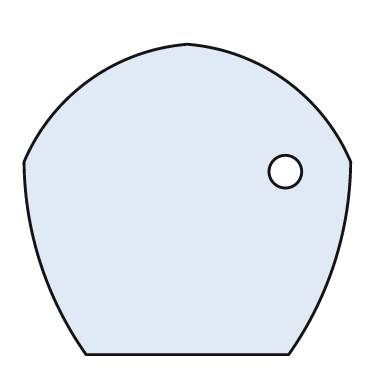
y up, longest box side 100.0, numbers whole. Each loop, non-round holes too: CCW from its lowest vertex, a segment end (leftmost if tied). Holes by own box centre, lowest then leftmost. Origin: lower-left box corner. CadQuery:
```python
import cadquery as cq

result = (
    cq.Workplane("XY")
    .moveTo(19.0, 0.0)
    .lineTo(81.0, 0.0)
    .threePointArc((95.0, 28.0), (100.0, 59.0))
    .threePointArc((80.0, 84.0), (50.0, 95.0))
    .threePointArc((20.0, 84.0), (0.0, 59.0))
    .threePointArc((5.0, 28.0), (19.0, 0.0))
    .close()
    .moveTo(80.0, 56.0)
    .circle(5.0)
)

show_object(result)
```